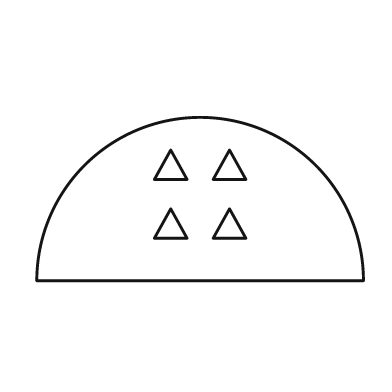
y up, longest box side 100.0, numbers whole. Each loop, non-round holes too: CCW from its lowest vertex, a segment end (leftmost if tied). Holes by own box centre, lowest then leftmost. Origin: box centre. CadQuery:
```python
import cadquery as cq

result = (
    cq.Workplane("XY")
    .moveTo(-50.0, -25.0)
    .lineTo(50.0, -25.0)
    .threePointArc((0.0, 25.0), (-50.0, -25.0))
    .close()
    .moveTo(-14.0, -12.0)
    .lineTo(-4.0, -12.0)
    .lineTo(-9.0, -3.0)
    .close()
    .moveTo(4.0, -12.0)
    .lineTo(14.0, -12.0)
    .lineTo(9.0, -3.0)
    .close()
    .moveTo(-14.0, 6.0)
    .lineTo(-4.0, 6.0)
    .lineTo(-9.0, 15.0)
    .close()
    .moveTo(4.0, 6.0)
    .lineTo(14.0, 6.0)
    .lineTo(9.0, 15.0)
    .close()
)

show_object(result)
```